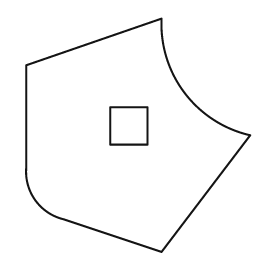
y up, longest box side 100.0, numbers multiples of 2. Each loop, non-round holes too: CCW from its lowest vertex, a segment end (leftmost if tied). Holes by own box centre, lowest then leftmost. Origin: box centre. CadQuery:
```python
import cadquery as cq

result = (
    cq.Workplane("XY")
    .moveTo(10.0, -50.0)
    .lineTo(48.0, 0.0)
    .threePointArc((20.0, 18.0), (10.0, 50.0))
    .lineTo(-48.0, 30.0)
    .lineTo(-48.0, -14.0)
    .threePointArc((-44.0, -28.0), (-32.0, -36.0))
    .close()
    .moveTo(-12.0, -4.0)
    .lineTo(4.0, -4.0)
    .lineTo(4.0, 12.0)
    .lineTo(-12.0, 12.0)
    .close()
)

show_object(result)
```